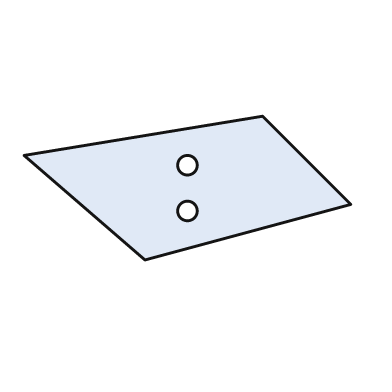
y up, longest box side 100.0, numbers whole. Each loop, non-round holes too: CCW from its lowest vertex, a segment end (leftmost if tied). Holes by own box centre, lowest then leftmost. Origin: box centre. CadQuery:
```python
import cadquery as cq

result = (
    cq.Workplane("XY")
    .moveTo(-13.0, -22.0)
    .lineTo(50.0, -5.0)
    .lineTo(23.0, 22.0)
    .lineTo(-50.0, 10.0)
    .close()
    .moveTo(0.0, -7.0)
    .circle(3.0)
    .moveTo(0.0, 7.0)
    .circle(3.0)
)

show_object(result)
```